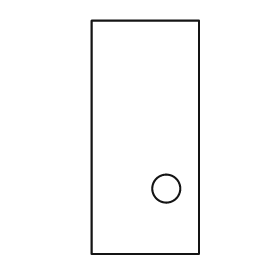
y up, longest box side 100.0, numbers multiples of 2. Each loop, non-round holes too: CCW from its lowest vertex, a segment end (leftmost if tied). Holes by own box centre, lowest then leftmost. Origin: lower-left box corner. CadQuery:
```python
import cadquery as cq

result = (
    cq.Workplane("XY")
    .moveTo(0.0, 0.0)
    .lineTo(46.0, 0.0)
    .lineTo(46.0, 100.0)
    .lineTo(0.0, 100.0)
    .close()
    .moveTo(32.0, 28.0)
    .circle(6.0)
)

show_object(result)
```